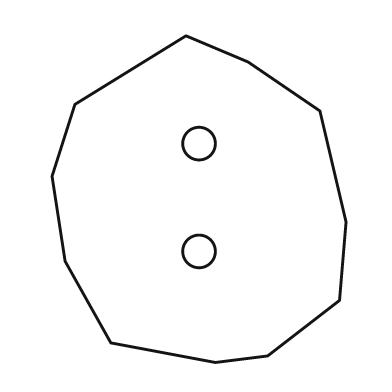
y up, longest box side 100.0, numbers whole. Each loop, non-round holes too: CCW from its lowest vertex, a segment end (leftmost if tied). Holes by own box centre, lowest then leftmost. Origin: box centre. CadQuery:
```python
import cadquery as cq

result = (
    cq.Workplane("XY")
    .moveTo(5.0, -50.0)
    .lineTo(21.0, -48.0)
    .lineTo(43.0, -31.0)
    .lineTo(45.0, -7.0)
    .lineTo(37.0, 27.0)
    .lineTo(15.0, 42.0)
    .lineTo(-4.0, 50.0)
    .lineTo(-38.0, 29.0)
    .lineTo(-45.0, 7.0)
    .lineTo(-41.0, -19.0)
    .lineTo(-27.0, -44.0)
    .close()
    .moveTo(0.0, -16.0)
    .circle(5.0)
    .moveTo(0.0, 17.0)
    .circle(5.0)
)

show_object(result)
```